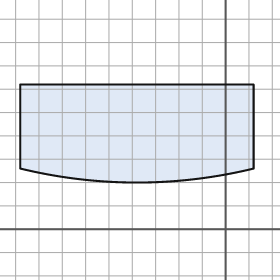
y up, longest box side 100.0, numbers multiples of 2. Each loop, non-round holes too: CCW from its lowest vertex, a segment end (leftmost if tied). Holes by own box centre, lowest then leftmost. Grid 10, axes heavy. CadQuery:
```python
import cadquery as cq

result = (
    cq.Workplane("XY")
    .moveTo(-88.0, 26.0)
    .threePointArc((-38.0, 20.0), (12.0, 26.0))
    .lineTo(12.0, 62.0)
    .lineTo(-88.0, 62.0)
    .close()
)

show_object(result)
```